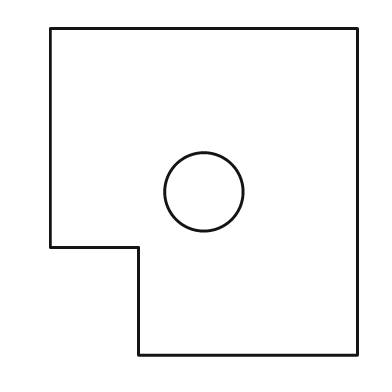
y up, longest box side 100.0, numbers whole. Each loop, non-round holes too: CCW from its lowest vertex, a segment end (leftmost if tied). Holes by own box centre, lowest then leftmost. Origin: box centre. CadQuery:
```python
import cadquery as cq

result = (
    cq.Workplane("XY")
    .moveTo(-20.0, -50.0)
    .lineTo(47.0, -50.0)
    .lineTo(47.0, 50.0)
    .lineTo(-47.0, 50.0)
    .lineTo(-47.0, -17.0)
    .lineTo(-20.0, -17.0)
    .close()
    .moveTo(0.0, 0.0)
    .circle(12.0)
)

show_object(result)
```